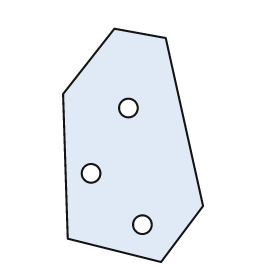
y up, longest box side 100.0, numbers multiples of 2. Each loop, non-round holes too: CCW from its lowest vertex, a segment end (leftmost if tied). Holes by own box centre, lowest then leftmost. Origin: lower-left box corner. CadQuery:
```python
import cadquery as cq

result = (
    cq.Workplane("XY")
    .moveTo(42.0, 0.0)
    .lineTo(60.0, 24.0)
    .lineTo(44.0, 96.0)
    .lineTo(22.0, 100.0)
    .lineTo(0.0, 72.0)
    .lineTo(2.0, 10.0)
    .close()
    .moveTo(34.0, 16.0)
    .circle(4.0)
    .moveTo(12.0, 38.0)
    .circle(4.0)
    .moveTo(28.0, 66.0)
    .circle(4.0)
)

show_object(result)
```